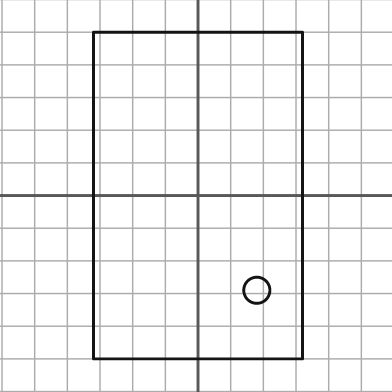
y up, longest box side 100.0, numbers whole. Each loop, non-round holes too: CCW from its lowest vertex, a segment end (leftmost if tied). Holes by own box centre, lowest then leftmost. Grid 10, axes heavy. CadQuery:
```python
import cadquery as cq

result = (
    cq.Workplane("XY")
    .moveTo(-32.0, -50.0)
    .lineTo(32.0, -50.0)
    .lineTo(32.0, 50.0)
    .lineTo(-32.0, 50.0)
    .close()
    .moveTo(18.0, -29.0)
    .circle(4.0)
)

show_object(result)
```